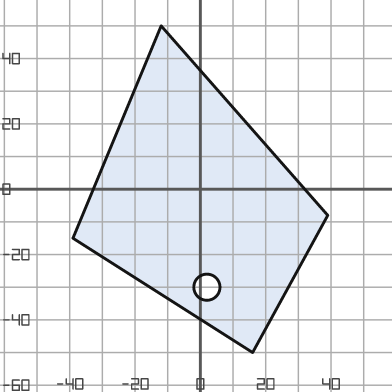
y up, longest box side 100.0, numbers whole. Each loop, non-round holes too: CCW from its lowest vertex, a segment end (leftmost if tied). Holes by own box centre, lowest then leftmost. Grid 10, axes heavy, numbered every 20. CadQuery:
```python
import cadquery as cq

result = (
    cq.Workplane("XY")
    .moveTo(16.0, -50.0)
    .lineTo(39.0, -8.0)
    .lineTo(-12.0, 50.0)
    .lineTo(-39.0, -15.0)
    .close()
    .moveTo(2.0, -30.0)
    .circle(4.0)
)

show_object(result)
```